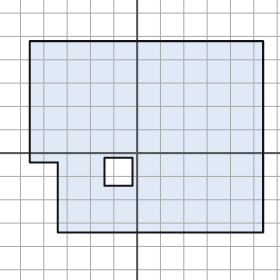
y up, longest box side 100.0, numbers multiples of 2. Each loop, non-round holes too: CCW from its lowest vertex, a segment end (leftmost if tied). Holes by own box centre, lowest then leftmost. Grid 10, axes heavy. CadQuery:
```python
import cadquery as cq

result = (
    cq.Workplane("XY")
    .moveTo(-34.0, -34.0)
    .lineTo(54.0, -34.0)
    .lineTo(54.0, 48.0)
    .lineTo(-46.0, 48.0)
    .lineTo(-46.0, -4.0)
    .lineTo(-34.0, -4.0)
    .close()
    .moveTo(-14.0, -14.0)
    .lineTo(-2.0, -14.0)
    .lineTo(-2.0, -2.0)
    .lineTo(-14.0, -2.0)
    .close()
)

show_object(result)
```